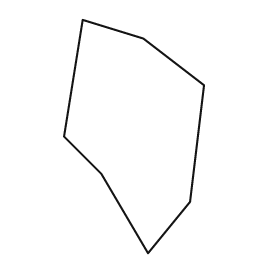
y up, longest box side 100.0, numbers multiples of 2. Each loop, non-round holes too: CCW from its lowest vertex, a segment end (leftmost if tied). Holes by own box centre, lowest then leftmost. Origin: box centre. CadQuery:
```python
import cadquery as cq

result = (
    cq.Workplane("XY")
    .moveTo(6.0, -50.0)
    .lineTo(24.0, -28.0)
    .lineTo(30.0, 22.0)
    .lineTo(4.0, 42.0)
    .lineTo(-22.0, 50.0)
    .lineTo(-30.0, 0.0)
    .lineTo(-14.0, -16.0)
    .close()
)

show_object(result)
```